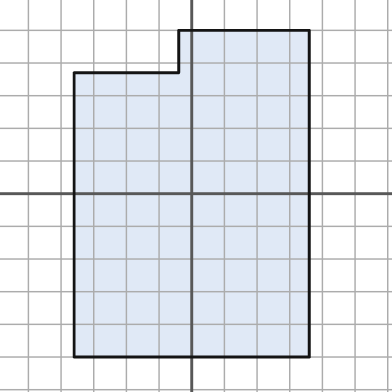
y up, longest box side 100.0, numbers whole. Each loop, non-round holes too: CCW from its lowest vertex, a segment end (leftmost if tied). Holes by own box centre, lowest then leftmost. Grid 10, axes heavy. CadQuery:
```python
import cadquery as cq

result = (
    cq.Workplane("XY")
    .moveTo(-36.0, -50.0)
    .lineTo(36.0, -50.0)
    .lineTo(36.0, 50.0)
    .lineTo(-4.0, 50.0)
    .lineTo(-4.0, 37.0)
    .lineTo(-36.0, 37.0)
    .close()
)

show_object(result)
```